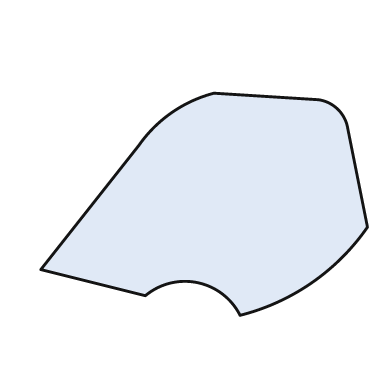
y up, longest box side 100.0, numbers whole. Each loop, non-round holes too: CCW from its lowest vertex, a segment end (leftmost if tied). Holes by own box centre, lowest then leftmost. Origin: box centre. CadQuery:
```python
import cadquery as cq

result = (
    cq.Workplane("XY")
    .moveTo(11.0, -34.0)
    .threePointArc((33.0, -24.0), (50.0, -7.0))
    .lineTo(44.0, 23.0)
    .threePointArc((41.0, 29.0), (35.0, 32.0))
    .lineTo(3.0, 34.0)
    .threePointArc((-10.0, 28.0), (-20.0, 18.0))
    .lineTo(-50.0, -20.0)
    .lineTo(-18.0, -28.0)
    .threePointArc((-2.0, -24.0), (11.0, -34.0))
    .close()
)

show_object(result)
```